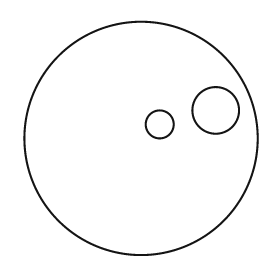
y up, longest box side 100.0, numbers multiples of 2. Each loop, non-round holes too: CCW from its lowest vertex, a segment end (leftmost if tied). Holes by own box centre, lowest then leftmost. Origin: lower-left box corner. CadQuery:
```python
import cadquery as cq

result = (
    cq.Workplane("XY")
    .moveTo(50.0, 50.0)
    .circle(50.0)
    .moveTo(58.0, 56.0)
    .circle(6.0)
    .moveTo(82.0, 62.0)
    .circle(10.0)
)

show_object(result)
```